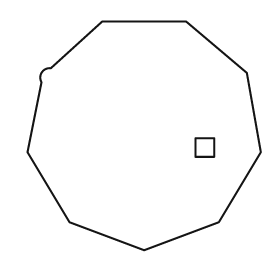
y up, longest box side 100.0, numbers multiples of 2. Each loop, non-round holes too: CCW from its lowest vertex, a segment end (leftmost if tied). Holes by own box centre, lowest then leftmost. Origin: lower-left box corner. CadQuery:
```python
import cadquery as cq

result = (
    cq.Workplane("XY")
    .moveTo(50.0, 0.0)
    .lineTo(82.0, 12.0)
    .lineTo(100.0, 42.0)
    .lineTo(94.0, 76.0)
    .lineTo(68.0, 98.0)
    .lineTo(32.0, 98.0)
    .lineTo(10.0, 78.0)
    .threePointArc((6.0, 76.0), (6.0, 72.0))
    .lineTo(0.0, 42.0)
    .lineTo(18.0, 12.0)
    .close()
    .moveTo(72.0, 40.0)
    .lineTo(80.0, 40.0)
    .lineTo(80.0, 48.0)
    .lineTo(72.0, 48.0)
    .close()
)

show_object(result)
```